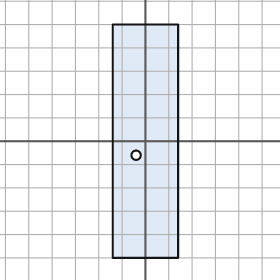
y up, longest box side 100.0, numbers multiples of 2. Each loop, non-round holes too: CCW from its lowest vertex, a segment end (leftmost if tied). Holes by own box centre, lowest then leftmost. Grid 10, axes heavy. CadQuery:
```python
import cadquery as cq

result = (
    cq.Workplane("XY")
    .moveTo(-14.0, -50.0)
    .lineTo(14.0, -50.0)
    .lineTo(14.0, 50.0)
    .lineTo(-14.0, 50.0)
    .close()
    .moveTo(-4.0, -6.0)
    .circle(2.0)
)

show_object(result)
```